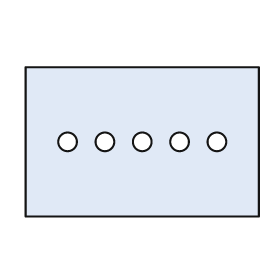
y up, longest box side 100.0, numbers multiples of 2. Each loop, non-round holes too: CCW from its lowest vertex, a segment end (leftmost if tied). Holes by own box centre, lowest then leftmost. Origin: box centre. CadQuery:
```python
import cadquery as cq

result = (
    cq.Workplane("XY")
    .moveTo(-50.0, -32.0)
    .lineTo(50.0, -32.0)
    .lineTo(50.0, 32.0)
    .lineTo(-50.0, 32.0)
    .close()
    .moveTo(-32.0, 0.0)
    .circle(4.0)
    .moveTo(-16.0, 0.0)
    .circle(4.0)
    .moveTo(0.0, 0.0)
    .circle(4.0)
    .moveTo(16.0, 0.0)
    .circle(4.0)
    .moveTo(32.0, 0.0)
    .circle(4.0)
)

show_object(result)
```